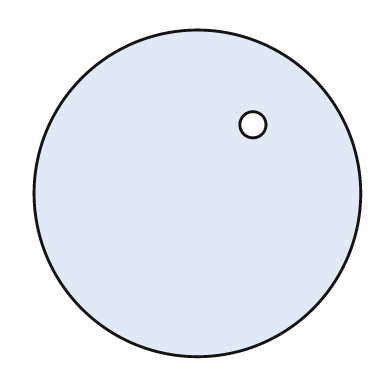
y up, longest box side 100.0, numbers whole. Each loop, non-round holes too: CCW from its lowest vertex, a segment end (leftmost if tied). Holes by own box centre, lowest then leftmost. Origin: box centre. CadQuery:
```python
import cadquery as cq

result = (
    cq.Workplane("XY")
    .moveTo(0.0, 0.0)
    .circle(50.0)
    .moveTo(17.0, 21.0)
    .circle(4.0)
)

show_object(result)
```